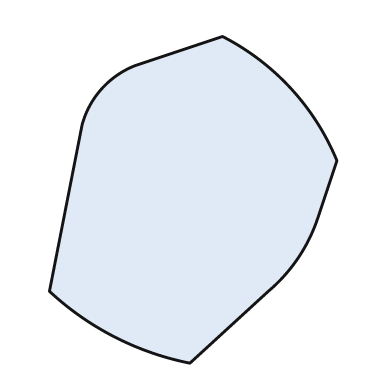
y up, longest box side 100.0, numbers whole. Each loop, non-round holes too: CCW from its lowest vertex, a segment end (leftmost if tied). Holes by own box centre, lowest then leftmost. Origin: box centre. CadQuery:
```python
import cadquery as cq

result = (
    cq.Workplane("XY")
    .moveTo(-1.0, -50.0)
    .lineTo(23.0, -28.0)
    .threePointArc((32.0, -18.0), (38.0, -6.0))
    .lineTo(44.0, 12.0)
    .threePointArc((30.0, 34.0), (9.0, 50.0))
    .lineTo(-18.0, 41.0)
    .threePointArc((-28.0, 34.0), (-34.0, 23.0))
    .lineTo(-44.0, -28.0)
    .threePointArc((-24.0, -42.0), (-1.0, -50.0))
    .close()
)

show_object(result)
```